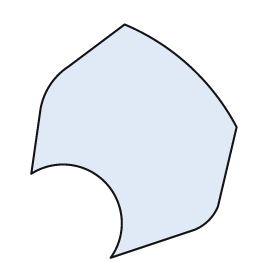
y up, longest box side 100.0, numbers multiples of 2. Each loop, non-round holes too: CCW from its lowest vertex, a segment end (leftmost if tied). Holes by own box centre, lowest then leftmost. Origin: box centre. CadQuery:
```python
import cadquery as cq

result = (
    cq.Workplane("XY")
    .moveTo(-10.0, -50.0)
    .lineTo(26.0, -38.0)
    .threePointArc((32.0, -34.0), (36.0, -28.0))
    .lineTo(44.0, 6.0)
    .threePointArc((24.0, 32.0), (-4.0, 50.0))
    .lineTo(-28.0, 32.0)
    .threePointArc((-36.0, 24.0), (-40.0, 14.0))
    .lineTo(-44.0, -14.0)
    .threePointArc((-12.0, -18.0), (-10.0, -50.0))
    .close()
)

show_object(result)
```